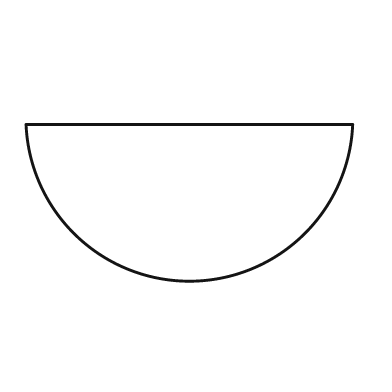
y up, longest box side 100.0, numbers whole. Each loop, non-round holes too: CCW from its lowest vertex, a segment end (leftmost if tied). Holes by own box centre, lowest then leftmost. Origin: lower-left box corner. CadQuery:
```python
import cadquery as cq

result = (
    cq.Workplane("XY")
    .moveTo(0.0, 48.0)
    .threePointArc((50.0, 0.0), (100.0, 48.0))
    .close()
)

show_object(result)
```